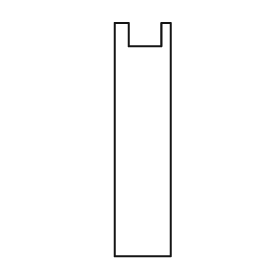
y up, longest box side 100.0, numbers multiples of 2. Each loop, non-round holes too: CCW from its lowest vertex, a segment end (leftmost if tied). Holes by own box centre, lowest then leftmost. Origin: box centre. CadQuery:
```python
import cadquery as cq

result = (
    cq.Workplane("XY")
    .moveTo(-12.0, -50.0)
    .lineTo(12.0, -50.0)
    .lineTo(12.0, 50.0)
    .lineTo(8.0, 50.0)
    .lineTo(8.0, 40.0)
    .lineTo(-6.0, 40.0)
    .lineTo(-6.0, 50.0)
    .lineTo(-12.0, 50.0)
    .close()
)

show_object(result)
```